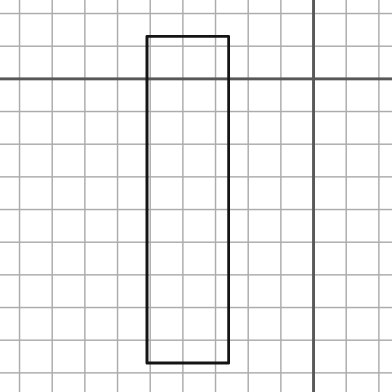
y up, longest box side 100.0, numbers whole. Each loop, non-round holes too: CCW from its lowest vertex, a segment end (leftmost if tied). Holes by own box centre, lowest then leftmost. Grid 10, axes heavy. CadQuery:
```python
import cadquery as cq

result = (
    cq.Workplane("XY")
    .moveTo(-51.0, -87.0)
    .lineTo(-26.0, -87.0)
    .lineTo(-26.0, 13.0)
    .lineTo(-51.0, 13.0)
    .close()
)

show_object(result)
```